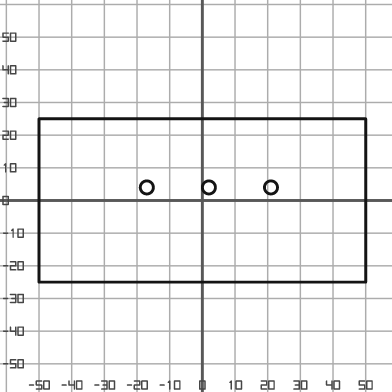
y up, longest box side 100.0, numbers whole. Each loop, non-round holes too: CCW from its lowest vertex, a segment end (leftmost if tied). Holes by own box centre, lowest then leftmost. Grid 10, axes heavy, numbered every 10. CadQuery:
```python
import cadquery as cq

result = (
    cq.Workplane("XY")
    .moveTo(-50.0, -25.0)
    .lineTo(50.0, -25.0)
    .lineTo(50.0, 25.0)
    .lineTo(-50.0, 25.0)
    .close()
    .moveTo(-17.0, 4.0)
    .circle(2.0)
    .moveTo(2.0, 4.0)
    .circle(2.0)
    .moveTo(21.0, 4.0)
    .circle(2.0)
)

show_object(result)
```